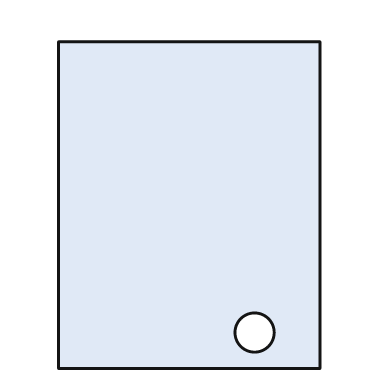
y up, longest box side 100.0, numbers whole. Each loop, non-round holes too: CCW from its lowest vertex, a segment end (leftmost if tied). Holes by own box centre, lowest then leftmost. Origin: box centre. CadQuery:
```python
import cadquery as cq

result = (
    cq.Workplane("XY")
    .moveTo(-40.0, -50.0)
    .lineTo(40.0, -50.0)
    .lineTo(40.0, 50.0)
    .lineTo(-40.0, 50.0)
    .close()
    .moveTo(20.0, -39.0)
    .circle(6.0)
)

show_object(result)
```